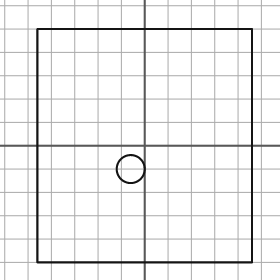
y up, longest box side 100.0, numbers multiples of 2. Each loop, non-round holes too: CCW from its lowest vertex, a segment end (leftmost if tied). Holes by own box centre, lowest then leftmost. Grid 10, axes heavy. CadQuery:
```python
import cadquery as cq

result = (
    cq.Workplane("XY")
    .moveTo(-46.0, -50.0)
    .lineTo(46.0, -50.0)
    .lineTo(46.0, 50.0)
    .lineTo(-46.0, 50.0)
    .close()
    .moveTo(-6.0, -10.0)
    .circle(6.0)
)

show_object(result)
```